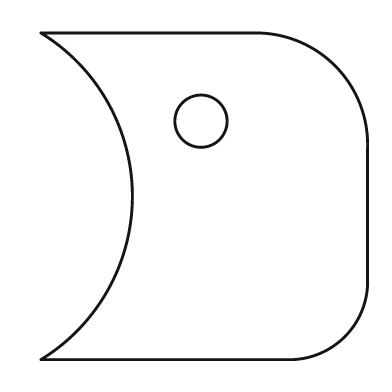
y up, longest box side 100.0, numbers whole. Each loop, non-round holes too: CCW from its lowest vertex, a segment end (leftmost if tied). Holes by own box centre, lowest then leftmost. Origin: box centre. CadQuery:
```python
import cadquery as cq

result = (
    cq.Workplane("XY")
    .moveTo(-50.0, -50.0)
    .lineTo(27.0, -50.0)
    .threePointArc((43.0, -43.0), (50.0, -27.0))
    .lineTo(50.0, 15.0)
    .threePointArc((40.0, 40.0), (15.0, 50.0))
    .lineTo(-50.0, 50.0)
    .threePointArc((-22.0, 0.0), (-50.0, -50.0))
    .close()
    .moveTo(-1.0, 23.0)
    .circle(8.0)
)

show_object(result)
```